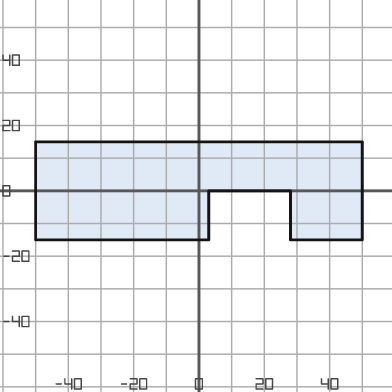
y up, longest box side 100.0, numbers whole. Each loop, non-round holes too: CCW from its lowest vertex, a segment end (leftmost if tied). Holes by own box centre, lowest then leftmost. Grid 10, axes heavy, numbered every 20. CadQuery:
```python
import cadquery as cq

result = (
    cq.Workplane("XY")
    .moveTo(-50.0, -15.0)
    .lineTo(3.0, -15.0)
    .lineTo(3.0, 0.0)
    .lineTo(28.0, 0.0)
    .lineTo(28.0, -15.0)
    .lineTo(50.0, -15.0)
    .lineTo(50.0, 15.0)
    .lineTo(-50.0, 15.0)
    .close()
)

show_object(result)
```